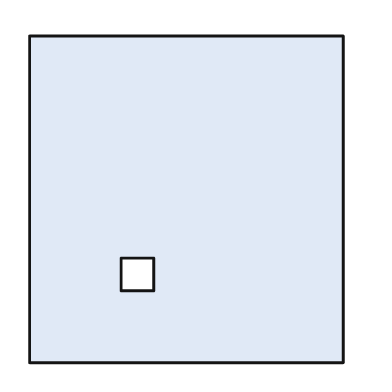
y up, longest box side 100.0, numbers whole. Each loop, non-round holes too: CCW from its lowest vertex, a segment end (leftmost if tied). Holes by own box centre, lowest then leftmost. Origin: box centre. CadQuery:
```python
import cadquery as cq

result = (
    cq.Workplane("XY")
    .moveTo(-48.0, -50.0)
    .lineTo(48.0, -50.0)
    .lineTo(48.0, 50.0)
    .lineTo(-48.0, 50.0)
    .close()
    .moveTo(-20.0, -28.0)
    .lineTo(-10.0, -28.0)
    .lineTo(-10.0, -18.0)
    .lineTo(-20.0, -18.0)
    .close()
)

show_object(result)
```